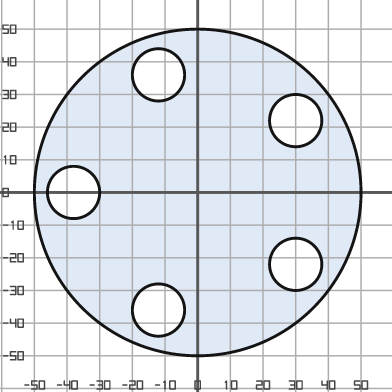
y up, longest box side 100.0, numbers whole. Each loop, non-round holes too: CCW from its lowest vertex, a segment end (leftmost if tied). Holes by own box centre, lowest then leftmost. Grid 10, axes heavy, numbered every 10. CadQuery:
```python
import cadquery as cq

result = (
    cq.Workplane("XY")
    .moveTo(0.0, 0.0)
    .circle(50.0)
    .moveTo(-12.0, -36.0)
    .circle(8.0)
    .moveTo(30.0, -22.0)
    .circle(8.0)
    .moveTo(-38.0, 0.0)
    .circle(8.0)
    .moveTo(30.0, 22.0)
    .circle(8.0)
    .moveTo(-12.0, 36.0)
    .circle(8.0)
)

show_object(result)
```